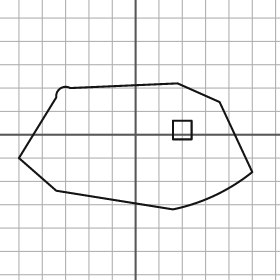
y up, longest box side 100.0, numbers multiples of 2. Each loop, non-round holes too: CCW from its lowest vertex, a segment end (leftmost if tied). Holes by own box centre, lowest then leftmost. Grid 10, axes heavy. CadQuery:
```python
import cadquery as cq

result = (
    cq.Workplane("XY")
    .moveTo(16.0, -32.0)
    .threePointArc((34.0, -26.0), (50.0, -16.0))
    .lineTo(36.0, 14.0)
    .lineTo(18.0, 22.0)
    .lineTo(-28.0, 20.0)
    .threePointArc((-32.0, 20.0), (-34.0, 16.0))
    .lineTo(-50.0, -10.0)
    .lineTo(-34.0, -24.0)
    .close()
    .moveTo(16.0, -2.0)
    .lineTo(24.0, -2.0)
    .lineTo(24.0, 6.0)
    .lineTo(16.0, 6.0)
    .close()
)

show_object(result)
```